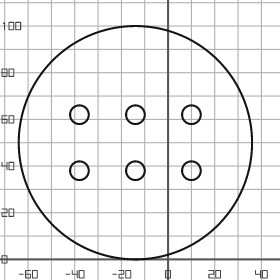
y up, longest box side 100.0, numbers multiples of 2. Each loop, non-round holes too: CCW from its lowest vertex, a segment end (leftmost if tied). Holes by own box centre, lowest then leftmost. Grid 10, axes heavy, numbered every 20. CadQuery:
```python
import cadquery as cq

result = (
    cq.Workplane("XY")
    .moveTo(-14.0, 50.0)
    .circle(50.0)
    .moveTo(-38.0, 38.0)
    .circle(4.0)
    .moveTo(-14.0, 38.0)
    .circle(4.0)
    .moveTo(10.0, 38.0)
    .circle(4.0)
    .moveTo(-38.0, 62.0)
    .circle(4.0)
    .moveTo(-14.0, 62.0)
    .circle(4.0)
    .moveTo(10.0, 62.0)
    .circle(4.0)
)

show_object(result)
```